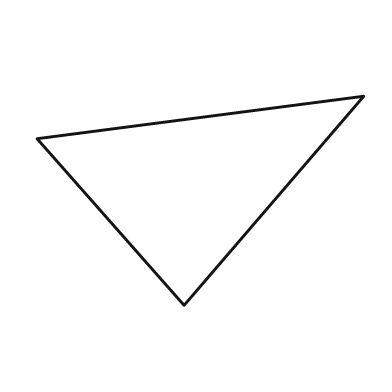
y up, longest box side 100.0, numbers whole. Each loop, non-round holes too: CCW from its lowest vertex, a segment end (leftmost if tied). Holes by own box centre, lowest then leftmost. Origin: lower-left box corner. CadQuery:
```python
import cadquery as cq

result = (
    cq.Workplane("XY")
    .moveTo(45.0, 0.0)
    .lineTo(100.0, 64.0)
    .lineTo(0.0, 51.0)
    .close()
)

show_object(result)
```